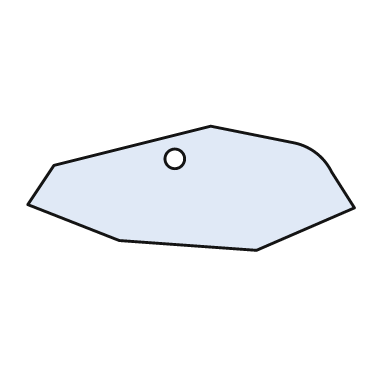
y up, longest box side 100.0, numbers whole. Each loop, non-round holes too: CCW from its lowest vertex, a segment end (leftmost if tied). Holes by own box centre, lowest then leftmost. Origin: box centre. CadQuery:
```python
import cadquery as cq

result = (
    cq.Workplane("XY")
    .moveTo(20.0, -19.0)
    .lineTo(50.0, -6.0)
    .lineTo(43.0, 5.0)
    .threePointArc((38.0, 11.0), (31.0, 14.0))
    .lineTo(6.0, 19.0)
    .lineTo(-42.0, 7.0)
    .lineTo(-50.0, -5.0)
    .lineTo(-22.0, -16.0)
    .close()
    .moveTo(-5.0, 9.0)
    .circle(3.0)
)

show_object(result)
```